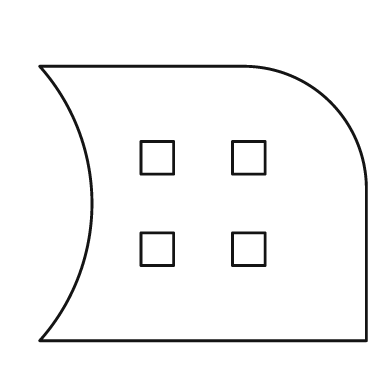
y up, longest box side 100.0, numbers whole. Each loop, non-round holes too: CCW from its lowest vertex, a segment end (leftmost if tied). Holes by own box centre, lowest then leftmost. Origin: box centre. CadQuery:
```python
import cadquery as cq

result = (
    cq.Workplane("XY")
    .moveTo(-50.0, -42.0)
    .lineTo(50.0, -42.0)
    .lineTo(50.0, 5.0)
    .threePointArc((39.0, 31.0), (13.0, 42.0))
    .lineTo(-50.0, 42.0)
    .threePointArc((-34.0, 0.0), (-50.0, -42.0))
    .close()
    .moveTo(-19.0, -19.0)
    .lineTo(-9.0, -19.0)
    .lineTo(-9.0, -9.0)
    .lineTo(-19.0, -9.0)
    .close()
    .moveTo(9.0, -19.0)
    .lineTo(19.0, -19.0)
    .lineTo(19.0, -9.0)
    .lineTo(9.0, -9.0)
    .close()
    .moveTo(-19.0, 9.0)
    .lineTo(-9.0, 9.0)
    .lineTo(-9.0, 19.0)
    .lineTo(-19.0, 19.0)
    .close()
    .moveTo(9.0, 9.0)
    .lineTo(19.0, 9.0)
    .lineTo(19.0, 19.0)
    .lineTo(9.0, 19.0)
    .close()
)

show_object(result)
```